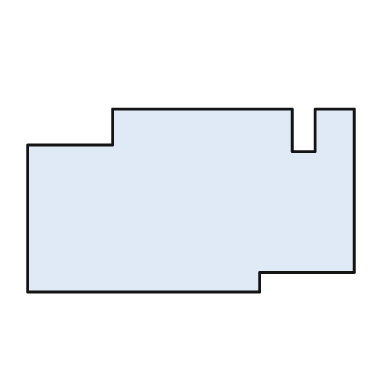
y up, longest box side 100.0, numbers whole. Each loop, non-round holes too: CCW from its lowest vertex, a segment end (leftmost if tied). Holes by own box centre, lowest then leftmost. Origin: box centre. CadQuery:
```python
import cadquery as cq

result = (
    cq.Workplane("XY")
    .moveTo(-50.0, -28.0)
    .lineTo(21.0, -28.0)
    .lineTo(21.0, -22.0)
    .lineTo(50.0, -22.0)
    .lineTo(50.0, 28.0)
    .lineTo(38.0, 28.0)
    .lineTo(38.0, 15.0)
    .lineTo(31.0, 15.0)
    .lineTo(31.0, 28.0)
    .lineTo(-24.0, 28.0)
    .lineTo(-24.0, 17.0)
    .lineTo(-50.0, 17.0)
    .close()
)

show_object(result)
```